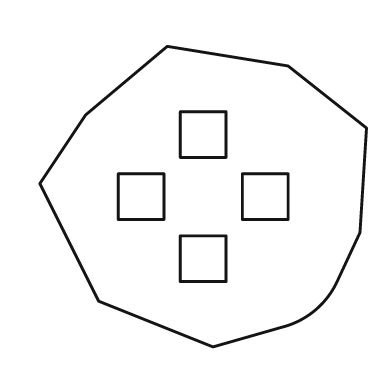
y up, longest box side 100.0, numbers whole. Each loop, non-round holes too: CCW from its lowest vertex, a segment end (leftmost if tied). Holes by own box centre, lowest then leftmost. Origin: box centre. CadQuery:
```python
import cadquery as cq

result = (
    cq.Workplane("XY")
    .moveTo(3.0, -46.0)
    .lineTo(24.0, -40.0)
    .threePointArc((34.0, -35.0), (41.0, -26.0))
    .lineTo(48.0, -11.0)
    .lineTo(50.0, 21.0)
    .lineTo(26.0, 40.0)
    .lineTo(-11.0, 46.0)
    .lineTo(-36.0, 25.0)
    .lineTo(-50.0, 4.0)
    .lineTo(-32.0, -32.0)
    .close()
    .moveTo(-7.0, -26.0)
    .lineTo(7.0, -26.0)
    .lineTo(7.0, -12.0)
    .lineTo(-7.0, -12.0)
    .close()
    .moveTo(-26.0, -7.0)
    .lineTo(-12.0, -7.0)
    .lineTo(-12.0, 7.0)
    .lineTo(-26.0, 7.0)
    .close()
    .moveTo(12.0, -7.0)
    .lineTo(26.0, -7.0)
    .lineTo(26.0, 7.0)
    .lineTo(12.0, 7.0)
    .close()
    .moveTo(-7.0, 12.0)
    .lineTo(7.0, 12.0)
    .lineTo(7.0, 26.0)
    .lineTo(-7.0, 26.0)
    .close()
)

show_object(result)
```